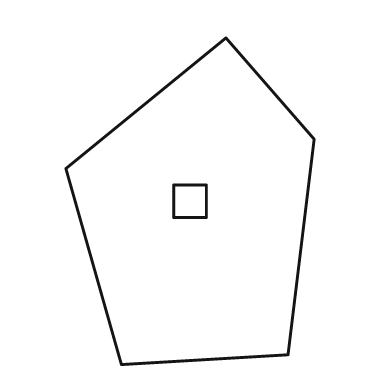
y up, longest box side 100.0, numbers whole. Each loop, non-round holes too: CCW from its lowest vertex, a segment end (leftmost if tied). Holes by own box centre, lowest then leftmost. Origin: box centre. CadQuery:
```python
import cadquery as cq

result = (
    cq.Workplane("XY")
    .moveTo(-21.0, -50.0)
    .lineTo(30.0, -47.0)
    .lineTo(38.0, 19.0)
    .lineTo(11.0, 50.0)
    .lineTo(-38.0, 10.0)
    .close()
    .moveTo(-5.0, -5.0)
    .lineTo(5.0, -5.0)
    .lineTo(5.0, 5.0)
    .lineTo(-5.0, 5.0)
    .close()
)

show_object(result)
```